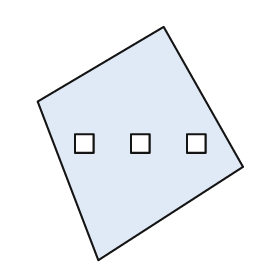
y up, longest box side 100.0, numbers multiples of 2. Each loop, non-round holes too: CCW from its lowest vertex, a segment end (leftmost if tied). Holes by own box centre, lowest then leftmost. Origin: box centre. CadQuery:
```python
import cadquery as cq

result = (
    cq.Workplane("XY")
    .moveTo(-18.0, -50.0)
    .lineTo(44.0, -10.0)
    .lineTo(10.0, 50.0)
    .lineTo(-44.0, 18.0)
    .close()
    .moveTo(-28.0, -4.0)
    .lineTo(-20.0, -4.0)
    .lineTo(-20.0, 4.0)
    .lineTo(-28.0, 4.0)
    .close()
    .moveTo(-4.0, -4.0)
    .lineTo(4.0, -4.0)
    .lineTo(4.0, 4.0)
    .lineTo(-4.0, 4.0)
    .close()
    .moveTo(20.0, -4.0)
    .lineTo(28.0, -4.0)
    .lineTo(28.0, 4.0)
    .lineTo(20.0, 4.0)
    .close()
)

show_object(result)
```